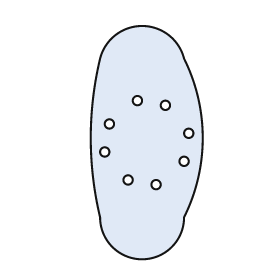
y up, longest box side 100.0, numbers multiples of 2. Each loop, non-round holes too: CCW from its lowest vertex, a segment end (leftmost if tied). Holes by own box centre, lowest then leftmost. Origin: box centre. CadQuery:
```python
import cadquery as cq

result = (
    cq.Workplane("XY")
    .moveTo(-20.0, -32.0)
    .threePointArc((-2.0, -50.0), (16.0, -32.0))
    .threePointArc((24.0, 2.0), (16.0, 36.0))
    .threePointArc((-2.0, 50.0), (-20.0, 36.0))
    .threePointArc((-24.0, 2.0), (-20.0, -32.0))
    .close()
    .moveTo(4.0, -18.0)
    .circle(2.0)
    .moveTo(-8.0, -16.0)
    .circle(2.0)
    .moveTo(16.0, -8.0)
    .circle(2.0)
    .moveTo(-18.0, -4.0)
    .circle(2.0)
    .moveTo(18.0, 4.0)
    .circle(2.0)
    .moveTo(-16.0, 8.0)
    .circle(2.0)
    .moveTo(8.0, 16.0)
    .circle(2.0)
    .moveTo(-4.0, 18.0)
    .circle(2.0)
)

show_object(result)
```